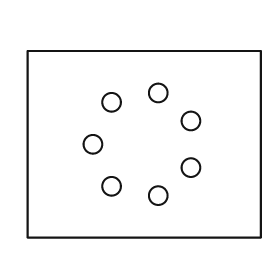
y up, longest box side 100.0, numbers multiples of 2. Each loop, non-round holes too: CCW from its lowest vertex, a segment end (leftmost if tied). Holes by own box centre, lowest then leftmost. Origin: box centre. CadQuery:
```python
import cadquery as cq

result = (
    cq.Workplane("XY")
    .moveTo(-50.0, -40.0)
    .lineTo(50.0, -40.0)
    .lineTo(50.0, 40.0)
    .lineTo(-50.0, 40.0)
    .close()
    .moveTo(6.0, -22.0)
    .circle(4.0)
    .moveTo(-14.0, -18.0)
    .circle(4.0)
    .moveTo(20.0, -10.0)
    .circle(4.0)
    .moveTo(-22.0, 0.0)
    .circle(4.0)
    .moveTo(20.0, 10.0)
    .circle(4.0)
    .moveTo(-14.0, 18.0)
    .circle(4.0)
    .moveTo(6.0, 22.0)
    .circle(4.0)
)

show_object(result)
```